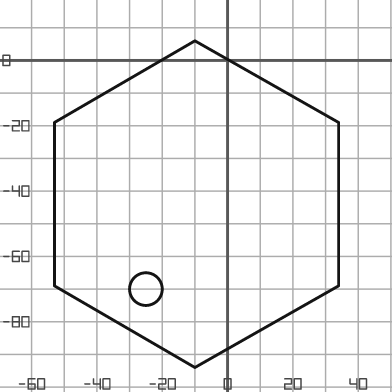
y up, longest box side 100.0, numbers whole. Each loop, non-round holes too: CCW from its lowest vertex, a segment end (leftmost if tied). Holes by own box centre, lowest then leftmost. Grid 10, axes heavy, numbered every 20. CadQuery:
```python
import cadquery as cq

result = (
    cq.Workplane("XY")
    .moveTo(-10.0, -94.0)
    .lineTo(34.0, -69.0)
    .lineTo(34.0, -19.0)
    .lineTo(-10.0, 6.0)
    .lineTo(-53.0, -19.0)
    .lineTo(-53.0, -69.0)
    .close()
    .moveTo(-25.0, -70.0)
    .circle(5.0)
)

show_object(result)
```